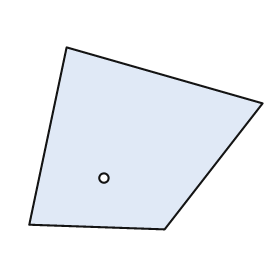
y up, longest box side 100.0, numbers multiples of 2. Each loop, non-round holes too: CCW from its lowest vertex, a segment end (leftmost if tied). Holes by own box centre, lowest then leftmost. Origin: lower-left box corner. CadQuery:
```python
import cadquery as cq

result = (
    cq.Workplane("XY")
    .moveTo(58.0, 0.0)
    .lineTo(100.0, 54.0)
    .lineTo(16.0, 78.0)
    .lineTo(0.0, 2.0)
    .close()
    .moveTo(32.0, 22.0)
    .circle(2.0)
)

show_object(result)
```